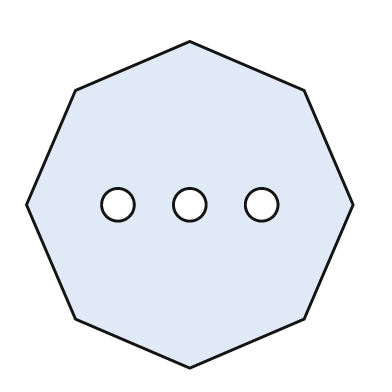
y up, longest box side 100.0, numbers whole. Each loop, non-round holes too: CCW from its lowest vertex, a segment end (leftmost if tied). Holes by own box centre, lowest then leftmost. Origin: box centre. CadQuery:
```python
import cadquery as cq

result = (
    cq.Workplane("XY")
    .moveTo(0.0, -50.0)
    .lineTo(35.0, -35.0)
    .lineTo(50.0, 0.0)
    .lineTo(35.0, 35.0)
    .lineTo(0.0, 50.0)
    .lineTo(-35.0, 35.0)
    .lineTo(-50.0, 0.0)
    .lineTo(-35.0, -35.0)
    .close()
    .moveTo(-22.0, 0.0)
    .circle(5.0)
    .moveTo(0.0, 0.0)
    .circle(5.0)
    .moveTo(22.0, 0.0)
    .circle(5.0)
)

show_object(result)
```